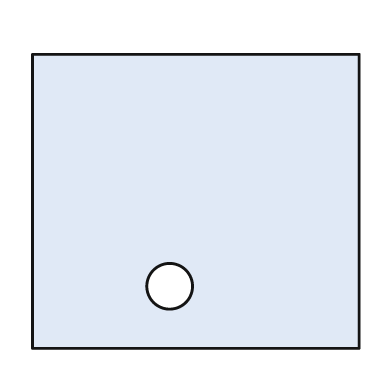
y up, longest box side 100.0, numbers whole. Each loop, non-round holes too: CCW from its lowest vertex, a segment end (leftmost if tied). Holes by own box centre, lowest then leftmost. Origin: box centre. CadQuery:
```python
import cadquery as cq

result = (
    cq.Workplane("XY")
    .moveTo(-50.0, -45.0)
    .lineTo(50.0, -45.0)
    .lineTo(50.0, 45.0)
    .lineTo(-50.0, 45.0)
    .close()
    .moveTo(-8.0, -26.0)
    .circle(7.0)
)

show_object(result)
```